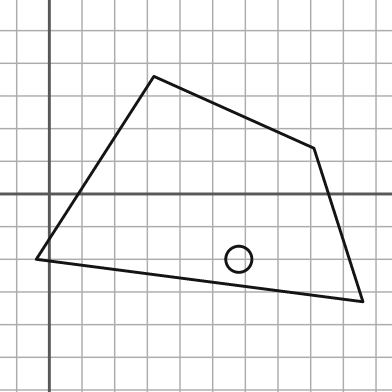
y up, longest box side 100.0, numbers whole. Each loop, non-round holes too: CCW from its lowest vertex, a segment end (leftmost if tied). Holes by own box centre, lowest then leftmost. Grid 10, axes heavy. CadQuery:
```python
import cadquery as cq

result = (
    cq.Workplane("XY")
    .moveTo(96.0, -33.0)
    .lineTo(81.0, 14.0)
    .lineTo(32.0, 36.0)
    .lineTo(-4.0, -20.0)
    .close()
    .moveTo(58.0, -20.0)
    .circle(4.0)
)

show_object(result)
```